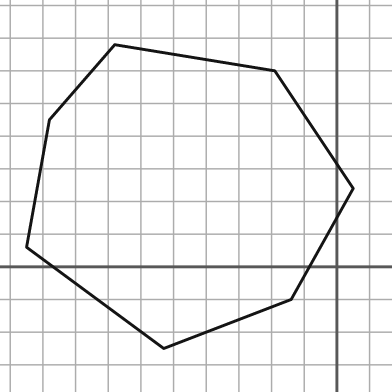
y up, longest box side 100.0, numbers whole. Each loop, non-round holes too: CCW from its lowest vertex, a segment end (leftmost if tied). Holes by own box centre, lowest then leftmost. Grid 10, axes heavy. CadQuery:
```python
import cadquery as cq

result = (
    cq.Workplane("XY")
    .moveTo(-53.0, -25.0)
    .lineTo(-14.0, -10.0)
    .lineTo(5.0, 24.0)
    .lineTo(-19.0, 60.0)
    .lineTo(-68.0, 68.0)
    .lineTo(-88.0, 45.0)
    .lineTo(-95.0, 6.0)
    .close()
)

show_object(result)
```